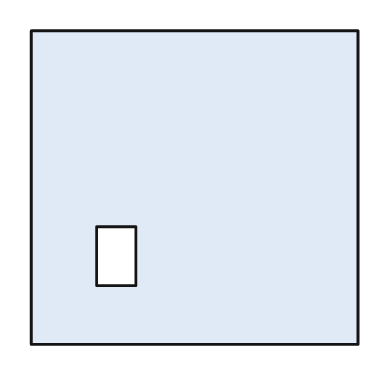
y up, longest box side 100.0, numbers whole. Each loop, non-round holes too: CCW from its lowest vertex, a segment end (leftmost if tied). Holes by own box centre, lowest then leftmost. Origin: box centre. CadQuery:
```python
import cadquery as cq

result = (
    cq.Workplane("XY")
    .moveTo(-50.0, -48.0)
    .lineTo(50.0, -48.0)
    .lineTo(50.0, 48.0)
    .lineTo(-50.0, 48.0)
    .close()
    .moveTo(-30.0, -30.0)
    .lineTo(-18.0, -30.0)
    .lineTo(-18.0, -12.0)
    .lineTo(-30.0, -12.0)
    .close()
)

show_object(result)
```